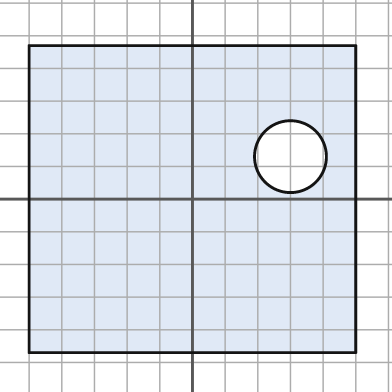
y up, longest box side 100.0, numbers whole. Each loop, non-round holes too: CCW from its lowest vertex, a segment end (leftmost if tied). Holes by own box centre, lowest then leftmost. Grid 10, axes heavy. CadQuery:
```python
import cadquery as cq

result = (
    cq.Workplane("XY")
    .moveTo(-50.0, -47.0)
    .lineTo(50.0, -47.0)
    .lineTo(50.0, 47.0)
    .lineTo(-50.0, 47.0)
    .close()
    .moveTo(30.0, 13.0)
    .circle(11.0)
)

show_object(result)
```